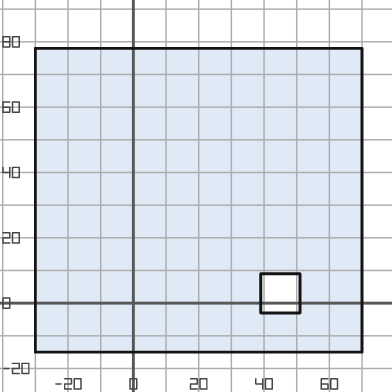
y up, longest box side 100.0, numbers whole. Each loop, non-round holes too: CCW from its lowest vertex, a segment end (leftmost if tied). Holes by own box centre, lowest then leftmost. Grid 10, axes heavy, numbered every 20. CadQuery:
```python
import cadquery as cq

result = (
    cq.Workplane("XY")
    .moveTo(-30.0, -15.0)
    .lineTo(70.0, -15.0)
    .lineTo(70.0, 78.0)
    .lineTo(-30.0, 78.0)
    .close()
    .moveTo(39.0, -3.0)
    .lineTo(51.0, -3.0)
    .lineTo(51.0, 9.0)
    .lineTo(39.0, 9.0)
    .close()
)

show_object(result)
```